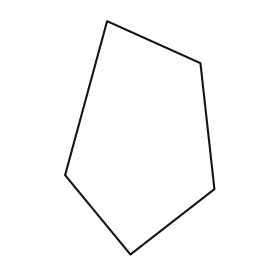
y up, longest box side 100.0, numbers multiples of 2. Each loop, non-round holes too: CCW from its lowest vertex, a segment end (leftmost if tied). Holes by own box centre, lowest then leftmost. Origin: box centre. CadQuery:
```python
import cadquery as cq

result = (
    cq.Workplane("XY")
    .moveTo(-4.0, -50.0)
    .lineTo(32.0, -22.0)
    .lineTo(26.0, 32.0)
    .lineTo(-14.0, 50.0)
    .lineTo(-32.0, -16.0)
    .close()
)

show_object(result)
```